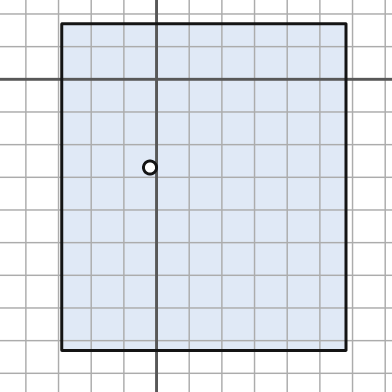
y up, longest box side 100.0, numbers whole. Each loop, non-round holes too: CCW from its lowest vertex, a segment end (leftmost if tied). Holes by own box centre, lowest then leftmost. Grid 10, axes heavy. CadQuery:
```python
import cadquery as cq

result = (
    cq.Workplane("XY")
    .moveTo(-29.0, -83.0)
    .lineTo(58.0, -83.0)
    .lineTo(58.0, 17.0)
    .lineTo(-29.0, 17.0)
    .close()
    .moveTo(-2.0, -27.0)
    .circle(2.0)
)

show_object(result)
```